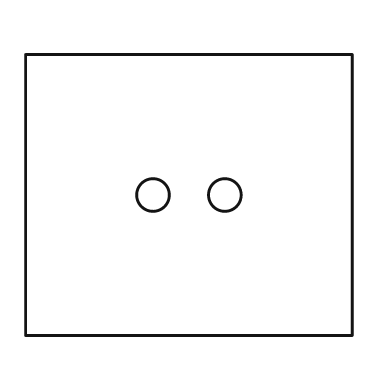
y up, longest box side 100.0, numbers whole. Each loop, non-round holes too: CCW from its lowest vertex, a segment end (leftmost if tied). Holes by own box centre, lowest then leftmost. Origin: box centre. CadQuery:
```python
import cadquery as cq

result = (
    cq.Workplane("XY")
    .moveTo(-50.0, -43.0)
    .lineTo(50.0, -43.0)
    .lineTo(50.0, 43.0)
    .lineTo(-50.0, 43.0)
    .close()
    .moveTo(-11.0, 0.0)
    .circle(5.0)
    .moveTo(11.0, 0.0)
    .circle(5.0)
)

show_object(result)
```